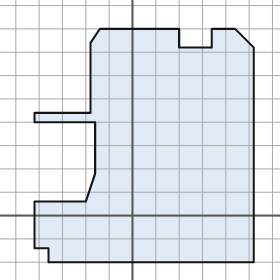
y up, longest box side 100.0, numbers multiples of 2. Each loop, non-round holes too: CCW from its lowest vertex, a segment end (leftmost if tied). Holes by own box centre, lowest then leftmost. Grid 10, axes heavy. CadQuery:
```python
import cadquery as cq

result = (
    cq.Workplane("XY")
    .moveTo(-36.0, -20.0)
    .lineTo(52.0, -20.0)
    .lineTo(52.0, 72.0)
    .lineTo(44.0, 80.0)
    .lineTo(34.0, 80.0)
    .lineTo(34.0, 72.0)
    .lineTo(20.0, 72.0)
    .lineTo(20.0, 80.0)
    .lineTo(-14.0, 80.0)
    .lineTo(-18.0, 74.0)
    .lineTo(-18.0, 44.0)
    .lineTo(-42.0, 44.0)
    .lineTo(-42.0, 40.0)
    .lineTo(-16.0, 40.0)
    .lineTo(-16.0, 18.0)
    .lineTo(-20.0, 6.0)
    .lineTo(-42.0, 6.0)
    .lineTo(-42.0, -14.0)
    .lineTo(-36.0, -14.0)
    .close()
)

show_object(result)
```